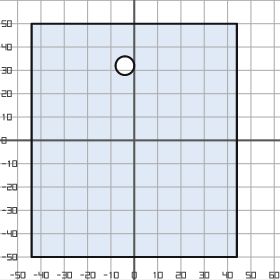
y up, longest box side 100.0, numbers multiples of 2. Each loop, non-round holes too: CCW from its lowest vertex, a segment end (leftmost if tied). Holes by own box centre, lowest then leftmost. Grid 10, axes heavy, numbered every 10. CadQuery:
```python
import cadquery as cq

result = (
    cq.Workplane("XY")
    .moveTo(-44.0, -50.0)
    .lineTo(44.0, -50.0)
    .lineTo(44.0, 50.0)
    .lineTo(-44.0, 50.0)
    .close()
    .moveTo(-4.0, 32.0)
    .circle(4.0)
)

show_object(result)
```